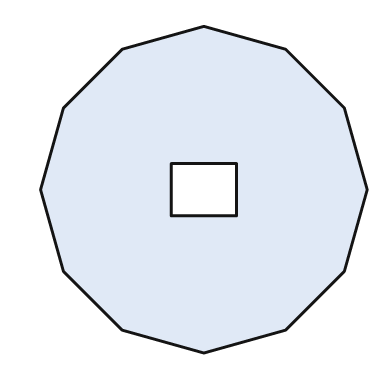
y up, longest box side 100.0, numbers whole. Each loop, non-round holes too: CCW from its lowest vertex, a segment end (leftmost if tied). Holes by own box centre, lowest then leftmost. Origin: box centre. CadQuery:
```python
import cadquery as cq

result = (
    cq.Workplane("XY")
    .moveTo(0.0, -50.0)
    .lineTo(25.0, -43.0)
    .lineTo(43.0, -25.0)
    .lineTo(50.0, 0.0)
    .lineTo(43.0, 25.0)
    .lineTo(25.0, 43.0)
    .lineTo(0.0, 50.0)
    .lineTo(-25.0, 43.0)
    .lineTo(-43.0, 25.0)
    .lineTo(-50.0, 0.0)
    .lineTo(-43.0, -25.0)
    .lineTo(-25.0, -43.0)
    .close()
    .moveTo(-10.0, -8.0)
    .lineTo(10.0, -8.0)
    .lineTo(10.0, 8.0)
    .lineTo(-10.0, 8.0)
    .close()
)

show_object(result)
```